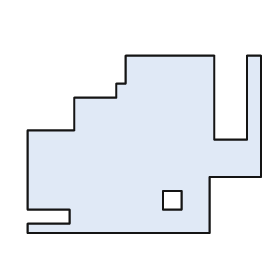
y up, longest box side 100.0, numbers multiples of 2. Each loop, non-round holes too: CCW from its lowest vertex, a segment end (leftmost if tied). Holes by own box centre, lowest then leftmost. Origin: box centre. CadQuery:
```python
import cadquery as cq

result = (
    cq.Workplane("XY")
    .moveTo(-50.0, -38.0)
    .lineTo(28.0, -38.0)
    .lineTo(28.0, -14.0)
    .lineTo(50.0, -14.0)
    .lineTo(50.0, 38.0)
    .lineTo(44.0, 38.0)
    .lineTo(44.0, 2.0)
    .lineTo(30.0, 2.0)
    .lineTo(30.0, 38.0)
    .lineTo(-8.0, 38.0)
    .lineTo(-8.0, 26.0)
    .lineTo(-12.0, 26.0)
    .lineTo(-12.0, 20.0)
    .lineTo(-30.0, 20.0)
    .lineTo(-30.0, 6.0)
    .lineTo(-50.0, 6.0)
    .lineTo(-50.0, -28.0)
    .lineTo(-32.0, -28.0)
    .lineTo(-32.0, -34.0)
    .lineTo(-50.0, -34.0)
    .close()
    .moveTo(8.0, -28.0)
    .lineTo(16.0, -28.0)
    .lineTo(16.0, -20.0)
    .lineTo(8.0, -20.0)
    .close()
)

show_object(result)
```